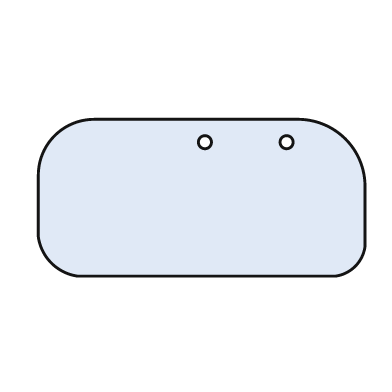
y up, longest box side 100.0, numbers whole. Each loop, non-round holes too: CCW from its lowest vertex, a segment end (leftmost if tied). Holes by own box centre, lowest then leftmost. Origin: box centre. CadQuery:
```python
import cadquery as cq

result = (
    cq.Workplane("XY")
    .moveTo(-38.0, -24.0)
    .lineTo(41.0, -24.0)
    .threePointArc((47.0, -21.0), (50.0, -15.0))
    .lineTo(50.0, 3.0)
    .threePointArc((44.0, 18.0), (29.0, 24.0))
    .lineTo(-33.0, 24.0)
    .threePointArc((-45.0, 19.0), (-50.0, 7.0))
    .lineTo(-50.0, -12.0)
    .threePointArc((-46.0, -20.0), (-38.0, -24.0))
    .close()
    .moveTo(1.0, 17.0)
    .circle(2.0)
    .moveTo(26.0, 17.0)
    .circle(2.0)
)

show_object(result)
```